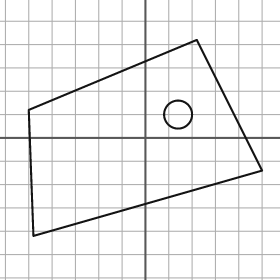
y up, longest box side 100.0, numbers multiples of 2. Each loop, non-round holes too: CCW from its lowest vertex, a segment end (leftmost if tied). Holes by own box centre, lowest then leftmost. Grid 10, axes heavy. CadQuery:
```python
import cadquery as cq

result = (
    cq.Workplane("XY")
    .moveTo(-48.0, -42.0)
    .lineTo(50.0, -14.0)
    .lineTo(22.0, 42.0)
    .lineTo(-50.0, 12.0)
    .close()
    .moveTo(14.0, 10.0)
    .circle(6.0)
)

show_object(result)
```